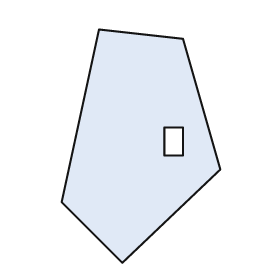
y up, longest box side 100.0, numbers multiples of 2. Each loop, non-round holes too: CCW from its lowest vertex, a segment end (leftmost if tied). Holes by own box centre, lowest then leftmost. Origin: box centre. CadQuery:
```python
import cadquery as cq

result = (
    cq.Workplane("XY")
    .moveTo(-8.0, -50.0)
    .lineTo(34.0, -10.0)
    .lineTo(18.0, 46.0)
    .lineTo(-18.0, 50.0)
    .lineTo(-34.0, -24.0)
    .close()
    .moveTo(10.0, -4.0)
    .lineTo(18.0, -4.0)
    .lineTo(18.0, 8.0)
    .lineTo(10.0, 8.0)
    .close()
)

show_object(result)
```